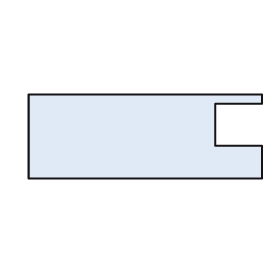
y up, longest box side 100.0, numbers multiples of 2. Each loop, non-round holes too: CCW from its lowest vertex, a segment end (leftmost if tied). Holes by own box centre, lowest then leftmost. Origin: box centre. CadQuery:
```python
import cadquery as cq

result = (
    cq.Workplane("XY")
    .moveTo(-50.0, -18.0)
    .lineTo(50.0, -18.0)
    .lineTo(50.0, -4.0)
    .lineTo(30.0, -4.0)
    .lineTo(30.0, 14.0)
    .lineTo(50.0, 14.0)
    .lineTo(50.0, 18.0)
    .lineTo(-50.0, 18.0)
    .close()
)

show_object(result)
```